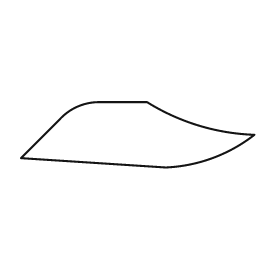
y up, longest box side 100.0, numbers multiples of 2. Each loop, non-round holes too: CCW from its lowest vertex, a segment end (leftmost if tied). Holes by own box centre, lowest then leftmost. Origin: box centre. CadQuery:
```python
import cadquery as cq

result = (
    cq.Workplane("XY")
    .moveTo(12.0, -14.0)
    .threePointArc((32.0, -10.0), (50.0, 0.0))
    .threePointArc((26.0, 4.0), (4.0, 14.0))
    .lineTo(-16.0, 14.0)
    .threePointArc((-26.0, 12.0), (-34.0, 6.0))
    .lineTo(-50.0, -10.0)
    .close()
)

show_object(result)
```